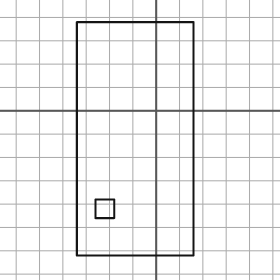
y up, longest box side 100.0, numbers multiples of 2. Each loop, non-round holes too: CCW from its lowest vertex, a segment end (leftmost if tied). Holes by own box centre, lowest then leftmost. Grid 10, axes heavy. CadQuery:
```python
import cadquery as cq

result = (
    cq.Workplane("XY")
    .moveTo(-34.0, -62.0)
    .lineTo(16.0, -62.0)
    .lineTo(16.0, 38.0)
    .lineTo(-34.0, 38.0)
    .close()
    .moveTo(-26.0, -46.0)
    .lineTo(-18.0, -46.0)
    .lineTo(-18.0, -38.0)
    .lineTo(-26.0, -38.0)
    .close()
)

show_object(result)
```